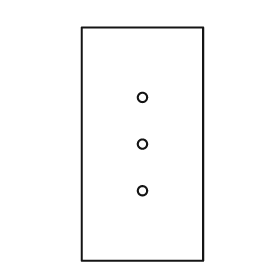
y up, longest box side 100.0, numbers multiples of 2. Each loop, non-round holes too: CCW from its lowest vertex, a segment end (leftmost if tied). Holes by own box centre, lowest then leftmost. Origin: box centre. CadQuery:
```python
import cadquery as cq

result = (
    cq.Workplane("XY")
    .moveTo(-26.0, -50.0)
    .lineTo(26.0, -50.0)
    .lineTo(26.0, 50.0)
    .lineTo(-26.0, 50.0)
    .close()
    .moveTo(0.0, -20.0)
    .circle(2.0)
    .moveTo(0.0, 0.0)
    .circle(2.0)
    .moveTo(0.0, 20.0)
    .circle(2.0)
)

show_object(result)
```